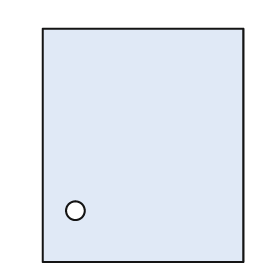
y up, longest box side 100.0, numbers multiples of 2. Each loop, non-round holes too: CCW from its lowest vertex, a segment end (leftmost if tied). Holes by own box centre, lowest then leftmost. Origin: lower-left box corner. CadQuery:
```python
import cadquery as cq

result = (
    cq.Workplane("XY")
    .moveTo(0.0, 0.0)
    .lineTo(86.0, 0.0)
    .lineTo(86.0, 100.0)
    .lineTo(0.0, 100.0)
    .close()
    .moveTo(14.0, 22.0)
    .circle(4.0)
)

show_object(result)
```